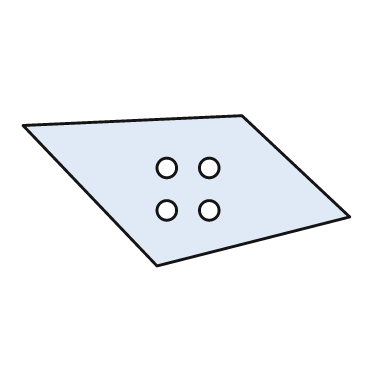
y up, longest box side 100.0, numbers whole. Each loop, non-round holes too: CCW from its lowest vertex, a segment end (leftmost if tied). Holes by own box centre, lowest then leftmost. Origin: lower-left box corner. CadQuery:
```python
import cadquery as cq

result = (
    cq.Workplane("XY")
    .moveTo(41.0, 0.0)
    .lineTo(100.0, 15.0)
    .lineTo(67.0, 46.0)
    .lineTo(0.0, 43.0)
    .close()
    .moveTo(44.0, 17.0)
    .circle(3.0)
    .moveTo(57.0, 17.0)
    .circle(3.0)
    .moveTo(44.0, 30.0)
    .circle(3.0)
    .moveTo(57.0, 30.0)
    .circle(3.0)
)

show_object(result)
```